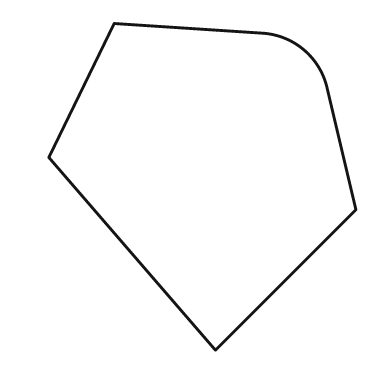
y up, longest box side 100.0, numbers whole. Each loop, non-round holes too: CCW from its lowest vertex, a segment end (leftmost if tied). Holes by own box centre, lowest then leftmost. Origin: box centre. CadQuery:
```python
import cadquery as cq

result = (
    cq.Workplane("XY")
    .moveTo(4.0, -50.0)
    .lineTo(47.0, -7.0)
    .lineTo(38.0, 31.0)
    .threePointArc((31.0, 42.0), (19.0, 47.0))
    .lineTo(-27.0, 50.0)
    .lineTo(-47.0, 9.0)
    .close()
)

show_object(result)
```